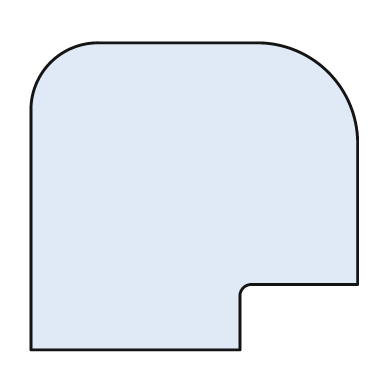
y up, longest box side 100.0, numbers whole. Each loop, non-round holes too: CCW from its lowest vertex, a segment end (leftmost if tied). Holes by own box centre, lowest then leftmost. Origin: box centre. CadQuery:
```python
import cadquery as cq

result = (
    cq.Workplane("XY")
    .moveTo(-50.0, -47.0)
    .lineTo(14.0, -47.0)
    .lineTo(14.0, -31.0)
    .threePointArc((15.0, -28.0), (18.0, -27.0))
    .lineTo(50.0, -27.0)
    .lineTo(50.0, 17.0)
    .threePointArc((41.0, 38.0), (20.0, 47.0))
    .lineTo(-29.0, 47.0)
    .threePointArc((-44.0, 41.0), (-50.0, 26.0))
    .close()
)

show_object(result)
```